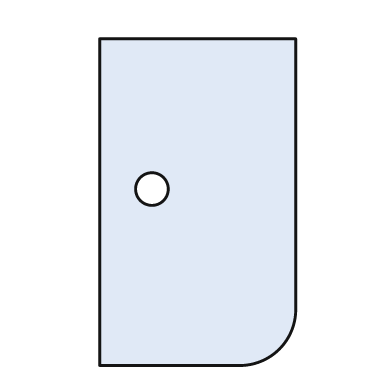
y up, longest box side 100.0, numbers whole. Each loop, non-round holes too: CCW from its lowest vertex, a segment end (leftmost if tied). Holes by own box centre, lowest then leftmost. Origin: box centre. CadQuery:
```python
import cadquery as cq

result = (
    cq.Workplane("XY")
    .moveTo(-30.0, -50.0)
    .lineTo(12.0, -50.0)
    .threePointArc((25.0, -45.0), (30.0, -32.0))
    .lineTo(30.0, 50.0)
    .lineTo(-30.0, 50.0)
    .close()
    .moveTo(-14.0, 4.0)
    .circle(5.0)
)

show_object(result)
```